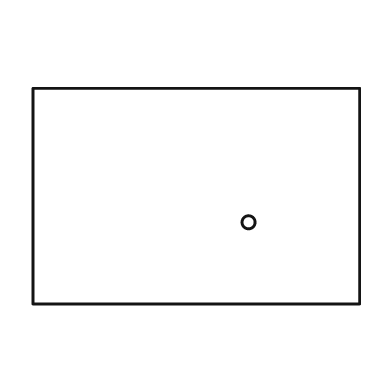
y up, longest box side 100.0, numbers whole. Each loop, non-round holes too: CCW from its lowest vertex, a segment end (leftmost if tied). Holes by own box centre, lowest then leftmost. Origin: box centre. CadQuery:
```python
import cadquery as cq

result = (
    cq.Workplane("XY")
    .moveTo(-50.0, -33.0)
    .lineTo(50.0, -33.0)
    .lineTo(50.0, 33.0)
    .lineTo(-50.0, 33.0)
    .close()
    .moveTo(16.0, -8.0)
    .circle(2.0)
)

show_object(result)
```